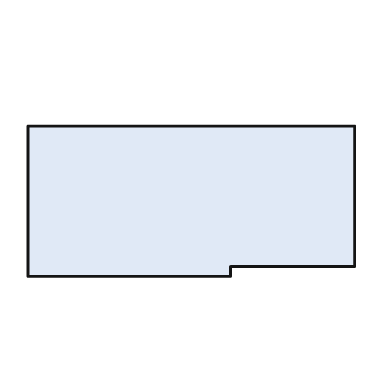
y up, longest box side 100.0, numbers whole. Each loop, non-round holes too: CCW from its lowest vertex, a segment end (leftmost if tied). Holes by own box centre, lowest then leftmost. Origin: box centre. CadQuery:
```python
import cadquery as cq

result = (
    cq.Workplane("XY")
    .moveTo(-50.0, -23.0)
    .lineTo(12.0, -23.0)
    .lineTo(12.0, -20.0)
    .lineTo(50.0, -20.0)
    .lineTo(50.0, 23.0)
    .lineTo(-50.0, 23.0)
    .close()
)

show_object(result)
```